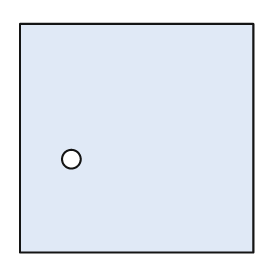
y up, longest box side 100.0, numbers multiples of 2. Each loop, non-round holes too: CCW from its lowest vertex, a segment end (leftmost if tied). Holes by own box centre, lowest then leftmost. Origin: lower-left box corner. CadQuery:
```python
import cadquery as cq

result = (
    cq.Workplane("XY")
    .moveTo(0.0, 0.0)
    .lineTo(100.0, 0.0)
    .lineTo(100.0, 98.0)
    .lineTo(0.0, 98.0)
    .close()
    .moveTo(22.0, 40.0)
    .circle(4.0)
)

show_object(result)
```